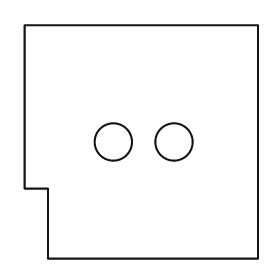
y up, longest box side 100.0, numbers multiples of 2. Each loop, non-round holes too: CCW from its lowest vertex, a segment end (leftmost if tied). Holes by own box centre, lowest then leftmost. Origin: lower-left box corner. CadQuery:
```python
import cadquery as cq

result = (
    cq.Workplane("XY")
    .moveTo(10.0, 0.0)
    .lineTo(100.0, 0.0)
    .lineTo(100.0, 100.0)
    .lineTo(0.0, 100.0)
    .lineTo(0.0, 30.0)
    .lineTo(10.0, 30.0)
    .close()
    .moveTo(38.0, 50.0)
    .circle(8.0)
    .moveTo(64.0, 50.0)
    .circle(8.0)
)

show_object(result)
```